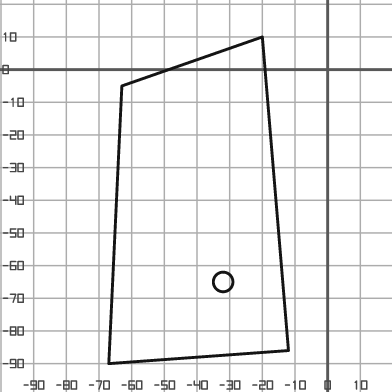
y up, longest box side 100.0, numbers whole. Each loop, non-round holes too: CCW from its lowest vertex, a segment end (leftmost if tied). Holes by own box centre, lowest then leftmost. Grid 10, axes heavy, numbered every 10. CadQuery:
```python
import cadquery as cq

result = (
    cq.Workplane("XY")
    .moveTo(-67.0, -90.0)
    .lineTo(-12.0, -86.0)
    .lineTo(-20.0, 10.0)
    .lineTo(-63.0, -5.0)
    .close()
    .moveTo(-32.0, -65.0)
    .circle(3.0)
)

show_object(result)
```